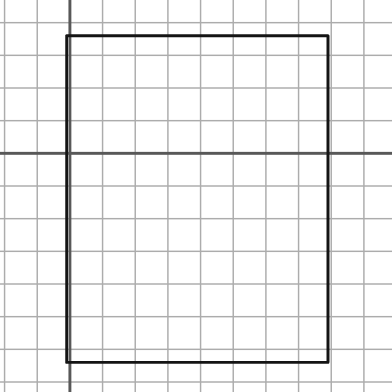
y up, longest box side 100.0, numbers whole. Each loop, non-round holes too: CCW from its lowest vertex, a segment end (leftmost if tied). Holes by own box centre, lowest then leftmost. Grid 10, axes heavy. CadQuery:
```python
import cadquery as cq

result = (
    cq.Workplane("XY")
    .moveTo(-1.0, -64.0)
    .lineTo(79.0, -64.0)
    .lineTo(79.0, 36.0)
    .lineTo(-1.0, 36.0)
    .close()
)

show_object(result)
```